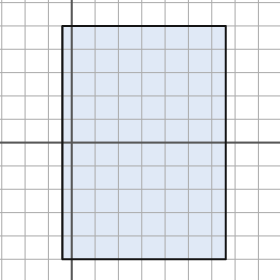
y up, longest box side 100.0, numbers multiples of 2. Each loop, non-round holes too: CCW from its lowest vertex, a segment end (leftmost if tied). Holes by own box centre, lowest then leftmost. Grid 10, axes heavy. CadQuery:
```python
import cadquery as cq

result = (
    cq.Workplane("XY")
    .moveTo(-4.0, -50.0)
    .lineTo(66.0, -50.0)
    .lineTo(66.0, 50.0)
    .lineTo(-4.0, 50.0)
    .close()
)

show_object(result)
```